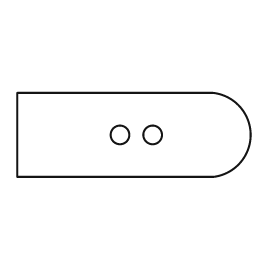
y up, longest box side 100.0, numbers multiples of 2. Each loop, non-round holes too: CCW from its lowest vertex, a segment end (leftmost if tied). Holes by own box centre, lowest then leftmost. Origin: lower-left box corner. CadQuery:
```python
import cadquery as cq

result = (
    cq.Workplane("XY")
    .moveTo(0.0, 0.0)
    .lineTo(84.0, 0.0)
    .threePointArc((100.0, 18.0), (84.0, 36.0))
    .lineTo(0.0, 36.0)
    .close()
    .moveTo(44.0, 18.0)
    .circle(4.0)
    .moveTo(58.0, 18.0)
    .circle(4.0)
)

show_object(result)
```